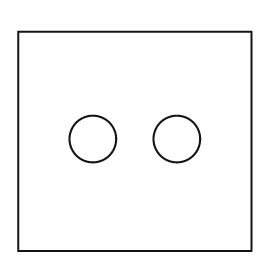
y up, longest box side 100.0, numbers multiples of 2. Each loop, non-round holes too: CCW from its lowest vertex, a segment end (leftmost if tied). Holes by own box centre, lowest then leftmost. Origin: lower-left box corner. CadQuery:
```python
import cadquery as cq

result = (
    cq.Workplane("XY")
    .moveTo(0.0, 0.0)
    .lineTo(100.0, 0.0)
    .lineTo(100.0, 94.0)
    .lineTo(0.0, 94.0)
    .close()
    .moveTo(32.0, 48.0)
    .circle(10.0)
    .moveTo(68.0, 48.0)
    .circle(10.0)
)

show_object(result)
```